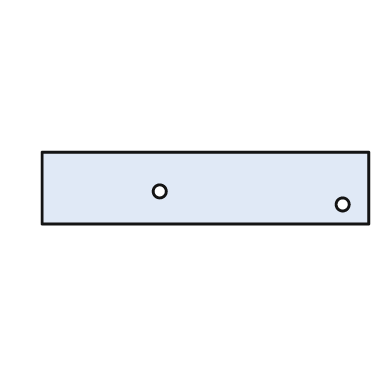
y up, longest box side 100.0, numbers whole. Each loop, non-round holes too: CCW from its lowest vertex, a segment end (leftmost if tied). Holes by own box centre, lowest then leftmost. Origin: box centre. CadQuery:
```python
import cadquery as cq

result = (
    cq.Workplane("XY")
    .moveTo(-50.0, -11.0)
    .lineTo(50.0, -11.0)
    .lineTo(50.0, 11.0)
    .lineTo(-50.0, 11.0)
    .close()
    .moveTo(42.0, -5.0)
    .circle(2.0)
    .moveTo(-14.0, -1.0)
    .circle(2.0)
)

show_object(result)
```